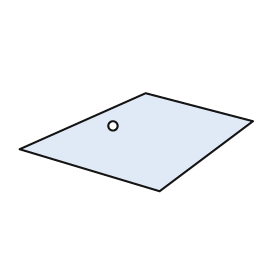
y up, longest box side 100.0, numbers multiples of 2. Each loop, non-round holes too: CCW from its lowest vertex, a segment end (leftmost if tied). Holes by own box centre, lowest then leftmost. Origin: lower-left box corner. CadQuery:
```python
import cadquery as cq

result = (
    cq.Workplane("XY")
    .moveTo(60.0, 0.0)
    .lineTo(100.0, 30.0)
    .lineTo(54.0, 42.0)
    .lineTo(0.0, 18.0)
    .close()
    .moveTo(40.0, 28.0)
    .circle(2.0)
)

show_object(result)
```